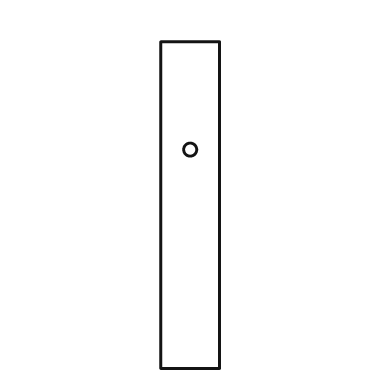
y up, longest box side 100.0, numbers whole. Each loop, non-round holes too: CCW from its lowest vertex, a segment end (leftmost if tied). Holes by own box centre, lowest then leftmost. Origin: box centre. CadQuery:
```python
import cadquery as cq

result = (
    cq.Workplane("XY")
    .moveTo(-9.0, -50.0)
    .lineTo(9.0, -50.0)
    .lineTo(9.0, 50.0)
    .lineTo(-9.0, 50.0)
    .close()
    .moveTo(0.0, 17.0)
    .circle(2.0)
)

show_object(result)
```